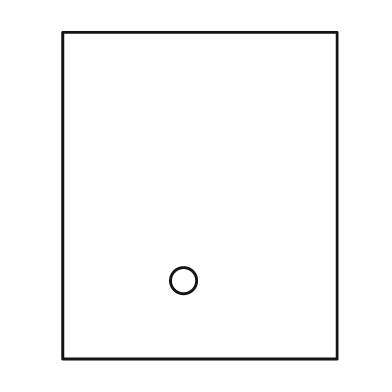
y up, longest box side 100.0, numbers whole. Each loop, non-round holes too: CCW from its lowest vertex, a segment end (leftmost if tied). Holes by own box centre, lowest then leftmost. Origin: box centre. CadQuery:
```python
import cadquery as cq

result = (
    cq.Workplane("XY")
    .moveTo(-42.0, -50.0)
    .lineTo(42.0, -50.0)
    .lineTo(42.0, 50.0)
    .lineTo(-42.0, 50.0)
    .close()
    .moveTo(-5.0, -26.0)
    .circle(4.0)
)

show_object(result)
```